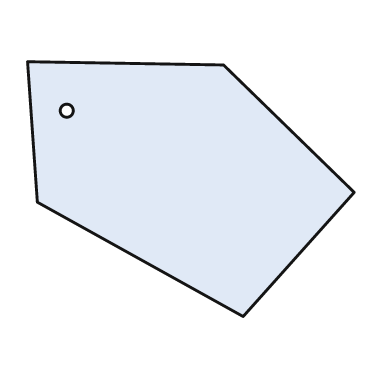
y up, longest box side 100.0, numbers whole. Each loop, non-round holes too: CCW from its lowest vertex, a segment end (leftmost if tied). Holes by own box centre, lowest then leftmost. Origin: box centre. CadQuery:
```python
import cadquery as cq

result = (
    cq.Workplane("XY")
    .moveTo(16.0, -39.0)
    .lineTo(50.0, -1.0)
    .lineTo(10.0, 38.0)
    .lineTo(-50.0, 39.0)
    .lineTo(-47.0, -4.0)
    .close()
    .moveTo(-38.0, 24.0)
    .circle(2.0)
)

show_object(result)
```